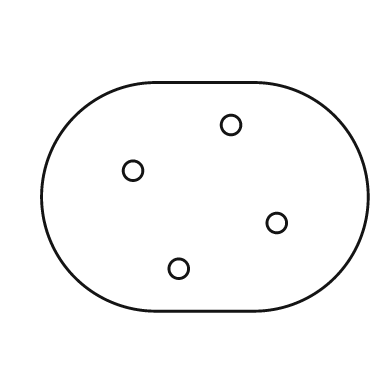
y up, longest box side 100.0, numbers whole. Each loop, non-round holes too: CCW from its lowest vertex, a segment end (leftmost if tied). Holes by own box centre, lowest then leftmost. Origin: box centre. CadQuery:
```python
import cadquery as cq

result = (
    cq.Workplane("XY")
    .moveTo(-15.0, -35.0)
    .lineTo(15.0, -35.0)
    .threePointArc((50.0, 0.0), (15.0, 35.0))
    .lineTo(-15.0, 35.0)
    .threePointArc((-50.0, 0.0), (-15.0, -35.0))
    .close()
    .moveTo(-8.0, -22.0)
    .circle(3.0)
    .moveTo(22.0, -8.0)
    .circle(3.0)
    .moveTo(-22.0, 8.0)
    .circle(3.0)
    .moveTo(8.0, 22.0)
    .circle(3.0)
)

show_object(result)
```